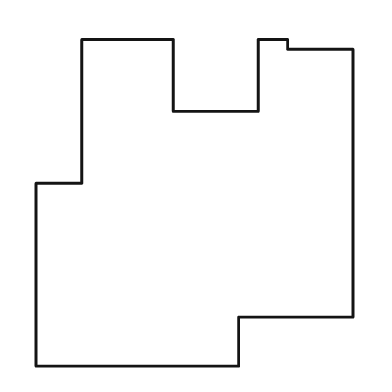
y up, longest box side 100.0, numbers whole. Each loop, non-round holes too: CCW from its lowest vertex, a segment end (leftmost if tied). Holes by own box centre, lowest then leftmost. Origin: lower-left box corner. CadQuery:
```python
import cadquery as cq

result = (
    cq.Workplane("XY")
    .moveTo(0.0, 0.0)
    .lineTo(62.0, 0.0)
    .lineTo(62.0, 15.0)
    .lineTo(97.0, 15.0)
    .lineTo(97.0, 97.0)
    .lineTo(77.0, 97.0)
    .lineTo(77.0, 100.0)
    .lineTo(68.0, 100.0)
    .lineTo(68.0, 78.0)
    .lineTo(42.0, 78.0)
    .lineTo(42.0, 100.0)
    .lineTo(14.0, 100.0)
    .lineTo(14.0, 56.0)
    .lineTo(0.0, 56.0)
    .close()
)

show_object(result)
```